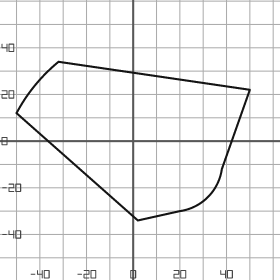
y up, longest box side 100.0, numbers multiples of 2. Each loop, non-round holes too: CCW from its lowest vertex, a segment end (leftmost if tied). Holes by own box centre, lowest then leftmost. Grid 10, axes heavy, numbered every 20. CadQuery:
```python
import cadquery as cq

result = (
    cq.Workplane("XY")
    .moveTo(2.0, -34.0)
    .lineTo(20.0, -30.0)
    .threePointArc((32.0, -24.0), (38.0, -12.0))
    .lineTo(50.0, 22.0)
    .lineTo(-32.0, 34.0)
    .threePointArc((-42.0, 24.0), (-50.0, 12.0))
    .close()
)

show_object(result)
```